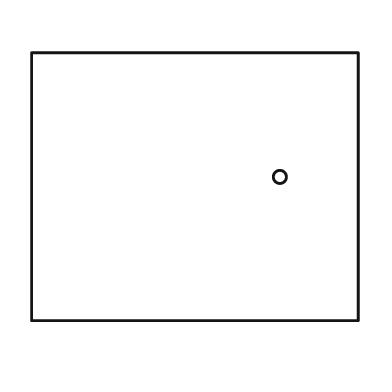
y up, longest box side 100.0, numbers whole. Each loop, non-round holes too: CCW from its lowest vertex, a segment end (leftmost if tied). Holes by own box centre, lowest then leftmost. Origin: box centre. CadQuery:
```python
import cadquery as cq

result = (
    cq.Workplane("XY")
    .moveTo(-50.0, -41.0)
    .lineTo(50.0, -41.0)
    .lineTo(50.0, 41.0)
    .lineTo(-50.0, 41.0)
    .close()
    .moveTo(26.0, 3.0)
    .circle(2.0)
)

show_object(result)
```